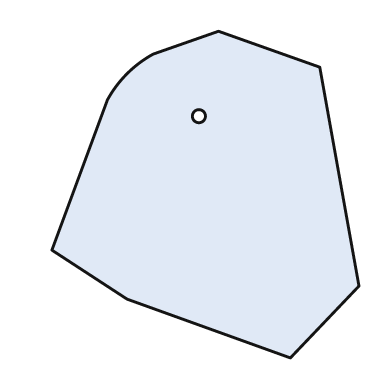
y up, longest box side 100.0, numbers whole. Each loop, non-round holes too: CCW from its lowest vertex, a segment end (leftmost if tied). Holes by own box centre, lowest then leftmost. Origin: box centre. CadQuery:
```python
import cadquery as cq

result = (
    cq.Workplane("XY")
    .moveTo(26.0, -50.0)
    .lineTo(47.0, -28.0)
    .lineTo(35.0, 39.0)
    .lineTo(4.0, 50.0)
    .lineTo(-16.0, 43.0)
    .threePointArc((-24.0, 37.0), (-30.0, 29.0))
    .lineTo(-47.0, -17.0)
    .lineTo(-24.0, -32.0)
    .close()
    .moveTo(-2.0, 24.0)
    .circle(2.0)
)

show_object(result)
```